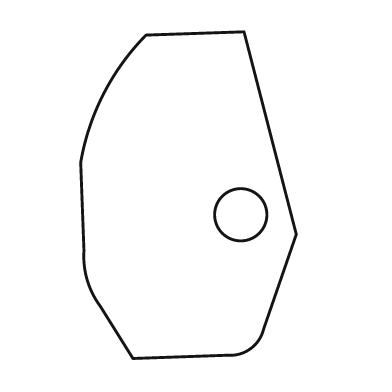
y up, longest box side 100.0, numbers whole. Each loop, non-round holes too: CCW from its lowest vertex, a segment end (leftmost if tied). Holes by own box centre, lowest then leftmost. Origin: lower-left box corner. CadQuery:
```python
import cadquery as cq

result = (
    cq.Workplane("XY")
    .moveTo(16.0, 0.0)
    .lineTo(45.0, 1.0)
    .threePointArc((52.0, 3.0), (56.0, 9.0))
    .lineTo(66.0, 38.0)
    .lineTo(50.0, 100.0)
    .lineTo(20.0, 99.0)
    .threePointArc((7.0, 81.0), (0.0, 60.0))
    .lineTo(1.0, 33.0)
    .threePointArc((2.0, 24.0), (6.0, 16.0))
    .close()
    .moveTo(49.0, 44.0)
    .circle(8.0)
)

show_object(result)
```